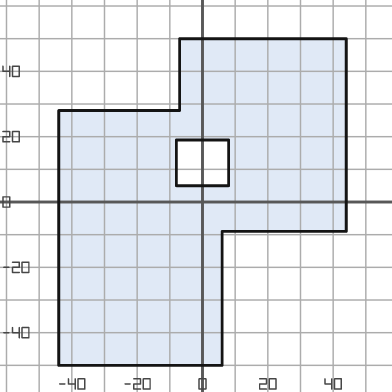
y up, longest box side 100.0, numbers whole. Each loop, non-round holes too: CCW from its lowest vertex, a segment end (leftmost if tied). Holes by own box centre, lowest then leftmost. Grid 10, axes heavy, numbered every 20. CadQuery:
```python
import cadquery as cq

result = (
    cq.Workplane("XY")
    .moveTo(-44.0, -50.0)
    .lineTo(6.0, -50.0)
    .lineTo(6.0, -9.0)
    .lineTo(44.0, -9.0)
    .lineTo(44.0, 50.0)
    .lineTo(-7.0, 50.0)
    .lineTo(-7.0, 28.0)
    .lineTo(-44.0, 28.0)
    .close()
    .moveTo(-8.0, 5.0)
    .lineTo(8.0, 5.0)
    .lineTo(8.0, 19.0)
    .lineTo(-8.0, 19.0)
    .close()
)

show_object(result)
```